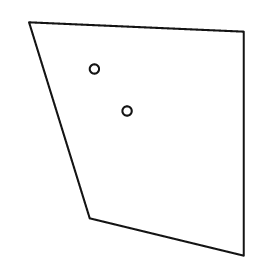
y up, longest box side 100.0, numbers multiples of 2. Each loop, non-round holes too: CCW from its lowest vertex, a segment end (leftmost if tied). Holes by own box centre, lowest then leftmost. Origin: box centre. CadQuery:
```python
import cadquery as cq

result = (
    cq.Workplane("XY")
    .moveTo(46.0, -50.0)
    .lineTo(46.0, 46.0)
    .lineTo(-46.0, 50.0)
    .lineTo(-20.0, -34.0)
    .close()
    .moveTo(-4.0, 12.0)
    .circle(2.0)
    .moveTo(-18.0, 30.0)
    .circle(2.0)
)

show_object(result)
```